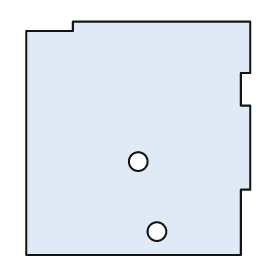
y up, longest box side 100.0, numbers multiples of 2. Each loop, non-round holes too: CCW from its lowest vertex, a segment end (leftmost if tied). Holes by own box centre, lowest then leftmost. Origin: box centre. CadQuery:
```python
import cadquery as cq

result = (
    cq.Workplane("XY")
    .moveTo(-48.0, -50.0)
    .lineTo(44.0, -50.0)
    .lineTo(44.0, -22.0)
    .lineTo(48.0, -22.0)
    .lineTo(48.0, 14.0)
    .lineTo(44.0, 14.0)
    .lineTo(44.0, 28.0)
    .lineTo(48.0, 28.0)
    .lineTo(48.0, 50.0)
    .lineTo(-28.0, 50.0)
    .lineTo(-28.0, 46.0)
    .lineTo(-48.0, 46.0)
    .close()
    .moveTo(8.0, -40.0)
    .circle(4.0)
    .moveTo(0.0, -10.0)
    .circle(4.0)
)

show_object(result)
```